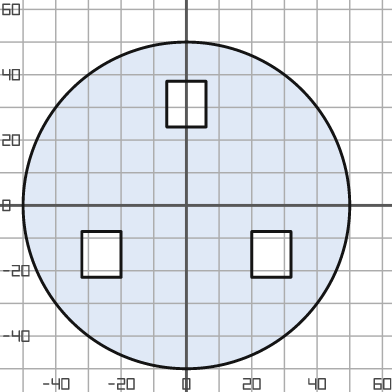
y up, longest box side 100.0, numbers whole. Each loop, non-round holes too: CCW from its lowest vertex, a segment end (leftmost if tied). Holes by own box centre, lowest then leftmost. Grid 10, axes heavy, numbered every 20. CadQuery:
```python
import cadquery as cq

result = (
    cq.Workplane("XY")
    .moveTo(0.0, 0.0)
    .circle(50.0)
    .moveTo(-32.0, -22.0)
    .lineTo(-20.0, -22.0)
    .lineTo(-20.0, -8.0)
    .lineTo(-32.0, -8.0)
    .close()
    .moveTo(20.0, -22.0)
    .lineTo(32.0, -22.0)
    .lineTo(32.0, -8.0)
    .lineTo(20.0, -8.0)
    .close()
    .moveTo(-6.0, 24.0)
    .lineTo(6.0, 24.0)
    .lineTo(6.0, 38.0)
    .lineTo(-6.0, 38.0)
    .close()
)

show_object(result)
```